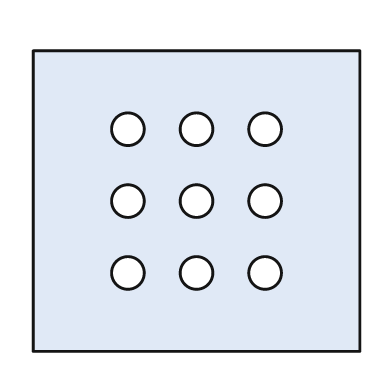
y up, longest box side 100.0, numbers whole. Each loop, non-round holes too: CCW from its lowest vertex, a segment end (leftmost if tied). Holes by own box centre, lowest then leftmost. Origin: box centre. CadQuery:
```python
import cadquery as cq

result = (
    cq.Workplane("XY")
    .moveTo(-50.0, -46.0)
    .lineTo(50.0, -46.0)
    .lineTo(50.0, 46.0)
    .lineTo(-50.0, 46.0)
    .close()
    .moveTo(-21.0, -22.0)
    .circle(5.0)
    .moveTo(0.0, -22.0)
    .circle(5.0)
    .moveTo(21.0, -22.0)
    .circle(5.0)
    .moveTo(-21.0, 0.0)
    .circle(5.0)
    .moveTo(0.0, 0.0)
    .circle(5.0)
    .moveTo(21.0, 0.0)
    .circle(5.0)
    .moveTo(-21.0, 22.0)
    .circle(5.0)
    .moveTo(0.0, 22.0)
    .circle(5.0)
    .moveTo(21.0, 22.0)
    .circle(5.0)
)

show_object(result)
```